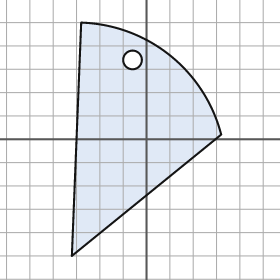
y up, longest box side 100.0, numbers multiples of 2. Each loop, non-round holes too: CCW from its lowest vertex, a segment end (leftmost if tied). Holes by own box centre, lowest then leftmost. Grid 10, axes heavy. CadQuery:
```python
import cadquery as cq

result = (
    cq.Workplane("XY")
    .moveTo(-32.0, -50.0)
    .lineTo(32.0, 2.0)
    .threePointArc((10.0, 36.0), (-28.0, 50.0))
    .close()
    .moveTo(-6.0, 34.0)
    .circle(4.0)
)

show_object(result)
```